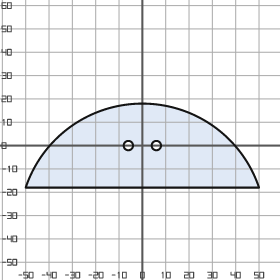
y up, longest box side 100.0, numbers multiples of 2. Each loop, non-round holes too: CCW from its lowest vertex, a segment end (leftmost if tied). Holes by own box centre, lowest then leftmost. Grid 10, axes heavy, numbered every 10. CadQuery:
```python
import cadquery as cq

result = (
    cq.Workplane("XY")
    .moveTo(-50.0, -18.0)
    .lineTo(50.0, -18.0)
    .threePointArc((0.0, 18.0), (-50.0, -18.0))
    .close()
    .moveTo(-6.0, 0.0)
    .circle(2.0)
    .moveTo(6.0, 0.0)
    .circle(2.0)
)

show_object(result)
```